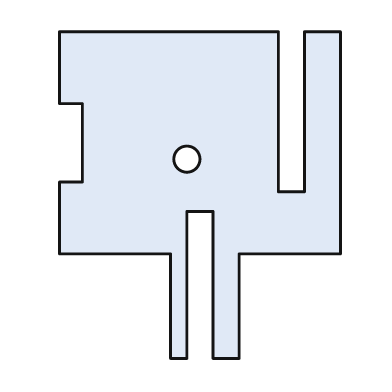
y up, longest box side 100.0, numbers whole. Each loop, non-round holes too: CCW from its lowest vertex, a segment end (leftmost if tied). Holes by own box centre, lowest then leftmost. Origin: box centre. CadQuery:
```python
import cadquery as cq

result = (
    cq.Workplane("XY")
    .moveTo(-9.0, -50.0)
    .lineTo(-4.0, -50.0)
    .lineTo(-4.0, -5.0)
    .lineTo(4.0, -5.0)
    .lineTo(4.0, -50.0)
    .lineTo(12.0, -50.0)
    .lineTo(12.0, -18.0)
    .lineTo(43.0, -18.0)
    .lineTo(43.0, 50.0)
    .lineTo(32.0, 50.0)
    .lineTo(32.0, 1.0)
    .lineTo(24.0, 1.0)
    .lineTo(24.0, 50.0)
    .lineTo(-43.0, 50.0)
    .lineTo(-43.0, 28.0)
    .lineTo(-36.0, 28.0)
    .lineTo(-36.0, 4.0)
    .lineTo(-43.0, 4.0)
    .lineTo(-43.0, -18.0)
    .lineTo(-9.0, -18.0)
    .close()
    .moveTo(-4.0, 11.0)
    .circle(4.0)
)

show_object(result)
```